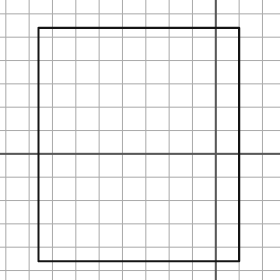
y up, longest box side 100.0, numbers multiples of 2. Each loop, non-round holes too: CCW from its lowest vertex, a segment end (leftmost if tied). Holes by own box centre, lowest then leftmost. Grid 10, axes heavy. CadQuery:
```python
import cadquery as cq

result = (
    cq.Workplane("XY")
    .moveTo(-76.0, -46.0)
    .lineTo(10.0, -46.0)
    .lineTo(10.0, 54.0)
    .lineTo(-76.0, 54.0)
    .close()
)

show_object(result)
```